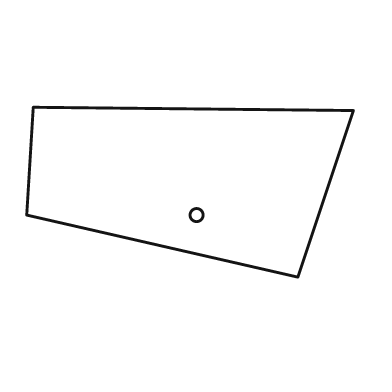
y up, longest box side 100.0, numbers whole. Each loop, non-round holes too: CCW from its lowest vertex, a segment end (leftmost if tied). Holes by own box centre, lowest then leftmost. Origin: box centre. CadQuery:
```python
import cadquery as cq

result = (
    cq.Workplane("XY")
    .moveTo(33.0, -26.0)
    .lineTo(50.0, 25.0)
    .lineTo(-48.0, 26.0)
    .lineTo(-50.0, -7.0)
    .close()
    .moveTo(2.0, -7.0)
    .circle(2.0)
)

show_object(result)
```